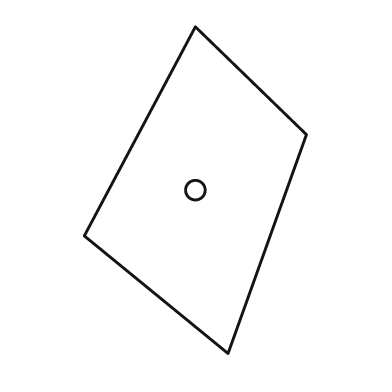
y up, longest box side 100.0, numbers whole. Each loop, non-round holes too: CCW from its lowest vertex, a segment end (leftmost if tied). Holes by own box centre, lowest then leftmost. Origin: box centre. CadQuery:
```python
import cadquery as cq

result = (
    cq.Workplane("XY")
    .moveTo(10.0, -50.0)
    .lineTo(34.0, 17.0)
    .lineTo(0.0, 50.0)
    .lineTo(-34.0, -14.0)
    .close()
    .moveTo(0.0, 0.0)
    .circle(3.0)
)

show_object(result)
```